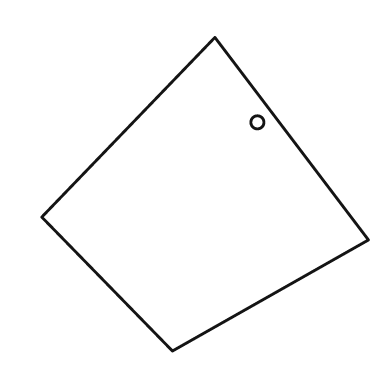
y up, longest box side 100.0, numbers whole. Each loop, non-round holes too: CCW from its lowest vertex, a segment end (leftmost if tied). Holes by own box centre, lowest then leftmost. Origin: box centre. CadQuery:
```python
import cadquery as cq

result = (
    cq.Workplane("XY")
    .moveTo(-10.0, -48.0)
    .lineTo(50.0, -14.0)
    .lineTo(3.0, 48.0)
    .lineTo(-50.0, -7.0)
    .close()
    .moveTo(16.0, 22.0)
    .circle(2.0)
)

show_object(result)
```